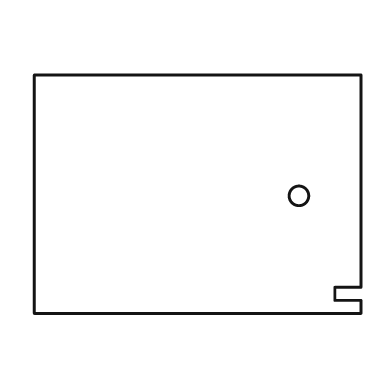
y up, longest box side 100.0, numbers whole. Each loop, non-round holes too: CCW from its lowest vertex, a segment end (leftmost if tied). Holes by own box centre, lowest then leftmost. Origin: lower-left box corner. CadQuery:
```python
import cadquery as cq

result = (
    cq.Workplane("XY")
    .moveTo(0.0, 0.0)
    .lineTo(100.0, 0.0)
    .lineTo(100.0, 4.0)
    .lineTo(92.0, 4.0)
    .lineTo(92.0, 8.0)
    .lineTo(100.0, 8.0)
    .lineTo(100.0, 73.0)
    .lineTo(0.0, 73.0)
    .close()
    .moveTo(81.0, 36.0)
    .circle(3.0)
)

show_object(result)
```